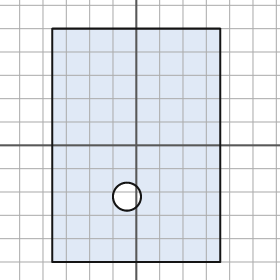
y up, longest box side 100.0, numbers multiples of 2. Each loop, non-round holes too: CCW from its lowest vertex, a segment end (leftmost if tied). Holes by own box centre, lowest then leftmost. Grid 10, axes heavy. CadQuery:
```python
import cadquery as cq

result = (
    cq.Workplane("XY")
    .moveTo(-36.0, -50.0)
    .lineTo(36.0, -50.0)
    .lineTo(36.0, 50.0)
    .lineTo(-36.0, 50.0)
    .close()
    .moveTo(-4.0, -22.0)
    .circle(6.0)
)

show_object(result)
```